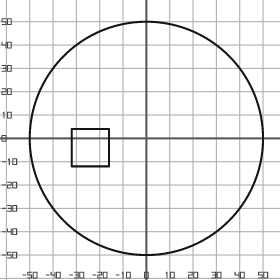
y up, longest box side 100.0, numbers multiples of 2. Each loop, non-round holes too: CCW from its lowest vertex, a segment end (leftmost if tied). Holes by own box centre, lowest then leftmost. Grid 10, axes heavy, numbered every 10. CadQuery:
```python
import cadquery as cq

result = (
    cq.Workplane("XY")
    .moveTo(0.0, 0.0)
    .circle(50.0)
    .moveTo(-32.0, -12.0)
    .lineTo(-16.0, -12.0)
    .lineTo(-16.0, 4.0)
    .lineTo(-32.0, 4.0)
    .close()
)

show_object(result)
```